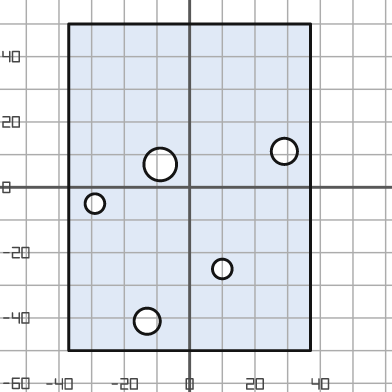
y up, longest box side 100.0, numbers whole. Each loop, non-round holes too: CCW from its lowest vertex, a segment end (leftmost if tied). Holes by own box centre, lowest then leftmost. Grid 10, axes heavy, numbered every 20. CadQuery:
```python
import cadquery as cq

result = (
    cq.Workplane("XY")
    .moveTo(-37.0, -50.0)
    .lineTo(37.0, -50.0)
    .lineTo(37.0, 50.0)
    .lineTo(-37.0, 50.0)
    .close()
    .moveTo(-13.0, -41.0)
    .circle(4.0)
    .moveTo(10.0, -25.0)
    .circle(3.0)
    .moveTo(-29.0, -5.0)
    .circle(3.0)
    .moveTo(-9.0, 7.0)
    .circle(5.0)
    .moveTo(29.0, 11.0)
    .circle(4.0)
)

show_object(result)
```